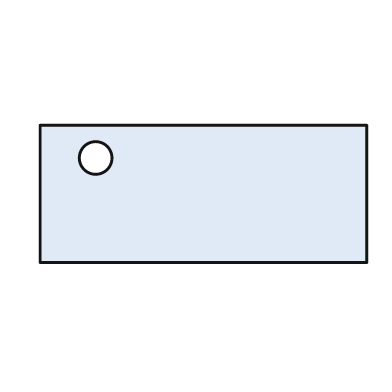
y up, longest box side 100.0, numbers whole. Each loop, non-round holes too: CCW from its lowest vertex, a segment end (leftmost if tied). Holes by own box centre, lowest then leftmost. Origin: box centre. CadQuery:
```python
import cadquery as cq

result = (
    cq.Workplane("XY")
    .moveTo(-50.0, -21.0)
    .lineTo(50.0, -21.0)
    .lineTo(50.0, 21.0)
    .lineTo(-50.0, 21.0)
    .close()
    .moveTo(-33.0, 11.0)
    .circle(5.0)
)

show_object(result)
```